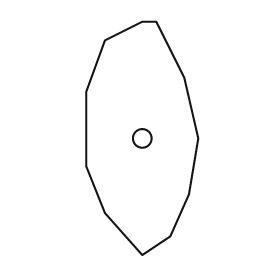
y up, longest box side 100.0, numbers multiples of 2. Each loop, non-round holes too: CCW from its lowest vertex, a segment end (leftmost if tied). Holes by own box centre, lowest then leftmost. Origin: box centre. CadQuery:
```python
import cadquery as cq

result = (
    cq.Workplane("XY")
    .moveTo(0.0, -50.0)
    .lineTo(12.0, -42.0)
    .lineTo(20.0, -24.0)
    .lineTo(24.0, 0.0)
    .lineTo(18.0, 26.0)
    .lineTo(6.0, 50.0)
    .lineTo(0.0, 50.0)
    .lineTo(-16.0, 42.0)
    .lineTo(-24.0, 20.0)
    .lineTo(-24.0, -12.0)
    .lineTo(-16.0, -32.0)
    .close()
    .moveTo(0.0, 0.0)
    .circle(4.0)
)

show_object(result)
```